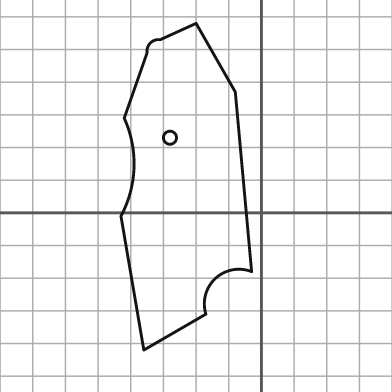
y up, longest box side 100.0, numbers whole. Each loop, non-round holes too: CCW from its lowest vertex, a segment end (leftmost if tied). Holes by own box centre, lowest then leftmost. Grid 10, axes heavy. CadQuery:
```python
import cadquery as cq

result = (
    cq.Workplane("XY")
    .moveTo(-36.0, -42.0)
    .lineTo(-17.0, -31.0)
    .threePointArc((-14.0, -20.0), (-3.0, -18.0))
    .lineTo(-8.0, 37.0)
    .lineTo(-20.0, 58.0)
    .lineTo(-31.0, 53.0)
    .threePointArc((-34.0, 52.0), (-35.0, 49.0))
    .lineTo(-42.0, 29.0)
    .threePointArc((-39.0, 14.0), (-43.0, -1.0))
    .close()
    .moveTo(-28.0, 23.0)
    .circle(2.0)
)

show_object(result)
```